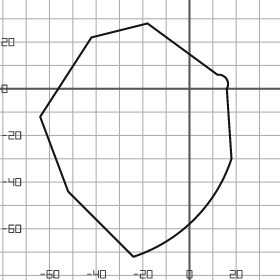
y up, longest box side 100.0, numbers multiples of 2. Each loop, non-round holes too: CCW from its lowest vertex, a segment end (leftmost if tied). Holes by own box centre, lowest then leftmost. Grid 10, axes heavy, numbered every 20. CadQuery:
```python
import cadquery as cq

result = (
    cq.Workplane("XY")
    .moveTo(-24.0, -72.0)
    .threePointArc((2.0, -56.0), (18.0, -30.0))
    .lineTo(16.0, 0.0)
    .threePointArc((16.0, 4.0), (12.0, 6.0))
    .lineTo(-18.0, 28.0)
    .lineTo(-42.0, 22.0)
    .lineTo(-64.0, -12.0)
    .lineTo(-52.0, -44.0)
    .close()
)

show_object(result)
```